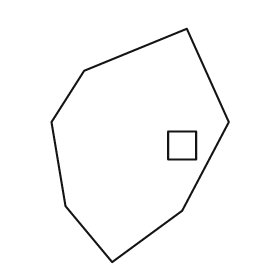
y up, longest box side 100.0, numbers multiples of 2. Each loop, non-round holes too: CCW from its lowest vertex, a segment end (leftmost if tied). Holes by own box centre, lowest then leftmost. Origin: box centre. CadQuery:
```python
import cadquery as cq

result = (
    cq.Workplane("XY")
    .moveTo(-12.0, -50.0)
    .lineTo(18.0, -28.0)
    .lineTo(38.0, 10.0)
    .lineTo(20.0, 50.0)
    .lineTo(-24.0, 32.0)
    .lineTo(-38.0, 10.0)
    .lineTo(-32.0, -26.0)
    .close()
    .moveTo(12.0, -6.0)
    .lineTo(24.0, -6.0)
    .lineTo(24.0, 6.0)
    .lineTo(12.0, 6.0)
    .close()
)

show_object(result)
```